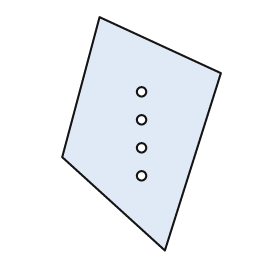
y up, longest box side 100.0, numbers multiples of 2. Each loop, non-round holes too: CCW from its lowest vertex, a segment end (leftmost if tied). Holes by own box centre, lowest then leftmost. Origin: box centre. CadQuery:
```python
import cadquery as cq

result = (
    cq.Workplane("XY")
    .moveTo(10.0, -50.0)
    .lineTo(34.0, 26.0)
    .lineTo(-18.0, 50.0)
    .lineTo(-34.0, -10.0)
    .close()
    .moveTo(0.0, -18.0)
    .circle(2.0)
    .moveTo(0.0, -6.0)
    .circle(2.0)
    .moveTo(0.0, 6.0)
    .circle(2.0)
    .moveTo(0.0, 18.0)
    .circle(2.0)
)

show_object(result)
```